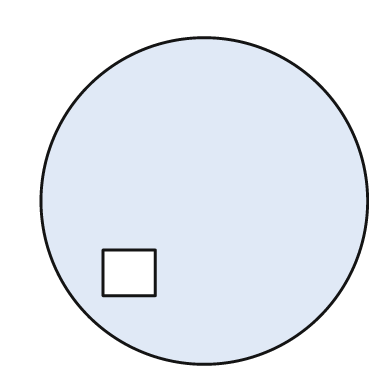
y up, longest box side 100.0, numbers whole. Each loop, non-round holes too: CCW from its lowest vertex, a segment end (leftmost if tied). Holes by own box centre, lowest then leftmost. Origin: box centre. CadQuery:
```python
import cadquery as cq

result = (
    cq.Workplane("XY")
    .moveTo(0.0, 0.0)
    .circle(50.0)
    .moveTo(-31.0, -29.0)
    .lineTo(-15.0, -29.0)
    .lineTo(-15.0, -15.0)
    .lineTo(-31.0, -15.0)
    .close()
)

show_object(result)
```